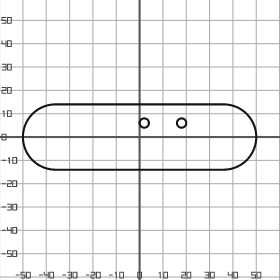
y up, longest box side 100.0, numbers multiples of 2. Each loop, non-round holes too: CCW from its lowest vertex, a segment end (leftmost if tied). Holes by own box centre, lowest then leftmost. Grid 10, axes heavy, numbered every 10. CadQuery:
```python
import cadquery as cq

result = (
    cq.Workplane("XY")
    .moveTo(-36.0, -14.0)
    .lineTo(36.0, -14.0)
    .threePointArc((50.0, 0.0), (36.0, 14.0))
    .lineTo(-36.0, 14.0)
    .threePointArc((-50.0, 0.0), (-36.0, -14.0))
    .close()
    .moveTo(2.0, 6.0)
    .circle(2.0)
    .moveTo(18.0, 6.0)
    .circle(2.0)
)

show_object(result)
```